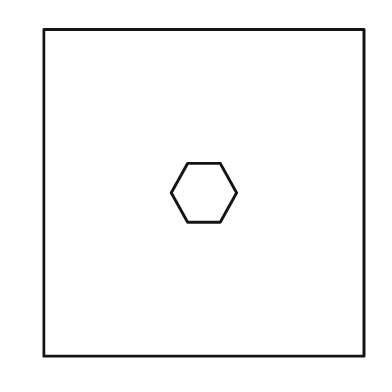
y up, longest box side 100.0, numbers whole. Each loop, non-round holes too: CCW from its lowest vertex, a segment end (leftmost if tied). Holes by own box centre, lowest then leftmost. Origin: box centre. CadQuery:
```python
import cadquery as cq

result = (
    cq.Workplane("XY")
    .moveTo(-49.0, -50.0)
    .lineTo(49.0, -50.0)
    .lineTo(49.0, 50.0)
    .lineTo(-49.0, 50.0)
    .close()
    .moveTo(-5.0, -9.0)
    .lineTo(5.0, -9.0)
    .lineTo(10.0, 0.0)
    .lineTo(5.0, 9.0)
    .lineTo(-5.0, 9.0)
    .lineTo(-10.0, 0.0)
    .close()
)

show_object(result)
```